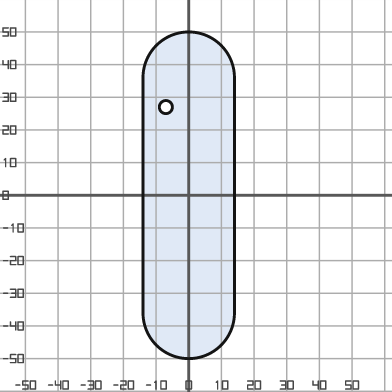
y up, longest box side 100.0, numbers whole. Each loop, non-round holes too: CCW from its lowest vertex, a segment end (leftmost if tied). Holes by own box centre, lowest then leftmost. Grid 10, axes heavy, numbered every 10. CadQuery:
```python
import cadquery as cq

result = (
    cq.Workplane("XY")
    .moveTo(-14.0, -36.0)
    .threePointArc((0.0, -50.0), (14.0, -36.0))
    .lineTo(14.0, 36.0)
    .threePointArc((0.0, 50.0), (-14.0, 36.0))
    .close()
    .moveTo(-7.0, 27.0)
    .circle(2.0)
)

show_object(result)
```